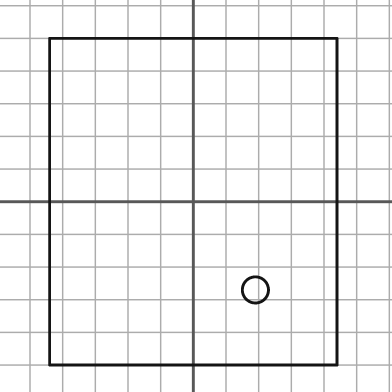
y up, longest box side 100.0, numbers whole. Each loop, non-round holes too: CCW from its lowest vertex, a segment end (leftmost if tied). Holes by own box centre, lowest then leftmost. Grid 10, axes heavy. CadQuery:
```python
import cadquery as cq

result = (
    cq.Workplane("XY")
    .moveTo(-44.0, -50.0)
    .lineTo(44.0, -50.0)
    .lineTo(44.0, 50.0)
    .lineTo(-44.0, 50.0)
    .close()
    .moveTo(19.0, -27.0)
    .circle(4.0)
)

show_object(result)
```